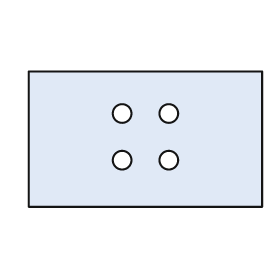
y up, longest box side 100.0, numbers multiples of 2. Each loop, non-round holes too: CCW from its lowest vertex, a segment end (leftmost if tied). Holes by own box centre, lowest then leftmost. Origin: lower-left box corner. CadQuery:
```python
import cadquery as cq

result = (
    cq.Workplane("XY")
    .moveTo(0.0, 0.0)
    .lineTo(100.0, 0.0)
    .lineTo(100.0, 58.0)
    .lineTo(0.0, 58.0)
    .close()
    .moveTo(40.0, 20.0)
    .circle(4.0)
    .moveTo(60.0, 20.0)
    .circle(4.0)
    .moveTo(40.0, 40.0)
    .circle(4.0)
    .moveTo(60.0, 40.0)
    .circle(4.0)
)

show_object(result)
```